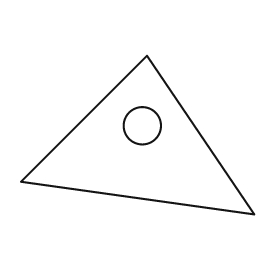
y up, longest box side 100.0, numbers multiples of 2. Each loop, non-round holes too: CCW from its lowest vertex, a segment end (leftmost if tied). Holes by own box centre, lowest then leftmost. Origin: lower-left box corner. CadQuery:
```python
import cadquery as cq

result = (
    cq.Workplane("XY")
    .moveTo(100.0, 0.0)
    .lineTo(54.0, 68.0)
    .lineTo(0.0, 14.0)
    .close()
    .moveTo(52.0, 38.0)
    .circle(8.0)
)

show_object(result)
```